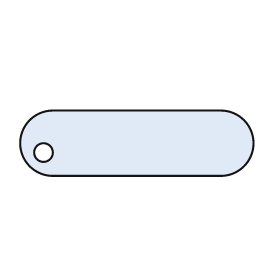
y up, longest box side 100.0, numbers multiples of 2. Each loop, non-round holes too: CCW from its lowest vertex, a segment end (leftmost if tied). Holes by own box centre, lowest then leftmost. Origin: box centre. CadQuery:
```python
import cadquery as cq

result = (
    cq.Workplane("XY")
    .moveTo(-36.0, -14.0)
    .lineTo(36.0, -14.0)
    .threePointArc((50.0, 0.0), (36.0, 14.0))
    .lineTo(-36.0, 14.0)
    .threePointArc((-50.0, 0.0), (-36.0, -14.0))
    .close()
    .moveTo(-40.0, -4.0)
    .circle(4.0)
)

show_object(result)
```